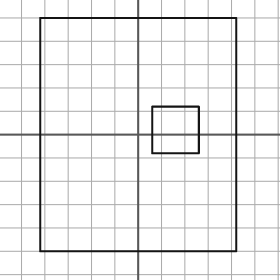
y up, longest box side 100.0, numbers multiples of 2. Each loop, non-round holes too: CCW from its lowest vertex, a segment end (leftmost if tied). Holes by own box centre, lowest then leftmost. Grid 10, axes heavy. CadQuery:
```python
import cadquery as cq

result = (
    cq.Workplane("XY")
    .moveTo(-42.0, -50.0)
    .lineTo(42.0, -50.0)
    .lineTo(42.0, 50.0)
    .lineTo(-42.0, 50.0)
    .close()
    .moveTo(6.0, -8.0)
    .lineTo(26.0, -8.0)
    .lineTo(26.0, 12.0)
    .lineTo(6.0, 12.0)
    .close()
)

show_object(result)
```